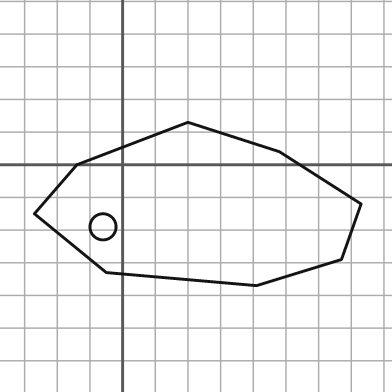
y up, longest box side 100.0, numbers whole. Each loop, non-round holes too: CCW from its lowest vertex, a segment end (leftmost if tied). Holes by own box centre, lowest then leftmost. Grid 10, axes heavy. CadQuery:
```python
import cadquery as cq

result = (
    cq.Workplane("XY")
    .moveTo(41.0, -37.0)
    .lineTo(67.0, -29.0)
    .lineTo(73.0, -12.0)
    .lineTo(48.0, 4.0)
    .lineTo(20.0, 13.0)
    .lineTo(-14.0, 0.0)
    .lineTo(-27.0, -15.0)
    .lineTo(-5.0, -33.0)
    .close()
    .moveTo(-6.0, -19.0)
    .circle(4.0)
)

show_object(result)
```